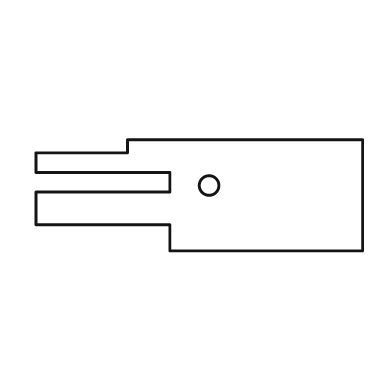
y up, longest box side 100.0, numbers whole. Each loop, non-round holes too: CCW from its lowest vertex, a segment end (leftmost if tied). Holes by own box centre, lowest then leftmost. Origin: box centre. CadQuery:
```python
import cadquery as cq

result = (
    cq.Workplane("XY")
    .moveTo(-9.0, -17.0)
    .lineTo(50.0, -17.0)
    .lineTo(50.0, 17.0)
    .lineTo(-22.0, 17.0)
    .lineTo(-22.0, 13.0)
    .lineTo(-50.0, 13.0)
    .lineTo(-50.0, 7.0)
    .lineTo(-9.0, 7.0)
    .lineTo(-9.0, 1.0)
    .lineTo(-50.0, 1.0)
    .lineTo(-50.0, -9.0)
    .lineTo(-9.0, -9.0)
    .close()
    .moveTo(3.0, 3.0)
    .circle(3.0)
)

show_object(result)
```